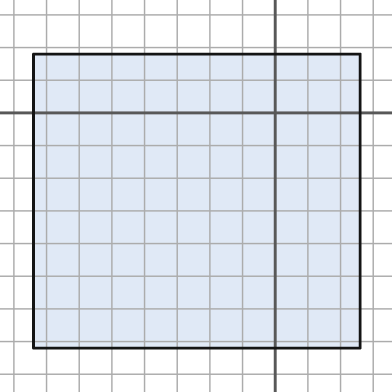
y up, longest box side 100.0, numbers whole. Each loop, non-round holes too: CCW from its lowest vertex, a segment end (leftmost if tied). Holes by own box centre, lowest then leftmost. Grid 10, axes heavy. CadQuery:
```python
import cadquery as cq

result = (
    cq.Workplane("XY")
    .moveTo(-74.0, -72.0)
    .lineTo(26.0, -72.0)
    .lineTo(26.0, 18.0)
    .lineTo(-74.0, 18.0)
    .close()
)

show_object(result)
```